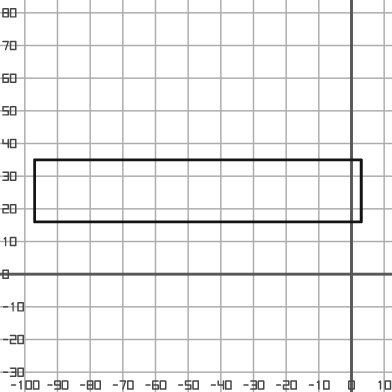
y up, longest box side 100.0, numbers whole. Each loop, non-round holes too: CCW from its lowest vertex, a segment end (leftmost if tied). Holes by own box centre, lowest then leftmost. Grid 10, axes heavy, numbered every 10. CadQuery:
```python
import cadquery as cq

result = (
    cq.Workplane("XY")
    .moveTo(-97.0, 16.0)
    .lineTo(3.0, 16.0)
    .lineTo(3.0, 35.0)
    .lineTo(-97.0, 35.0)
    .close()
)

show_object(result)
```